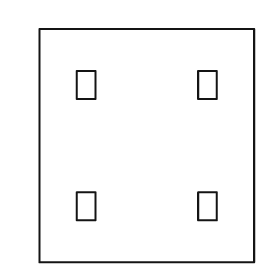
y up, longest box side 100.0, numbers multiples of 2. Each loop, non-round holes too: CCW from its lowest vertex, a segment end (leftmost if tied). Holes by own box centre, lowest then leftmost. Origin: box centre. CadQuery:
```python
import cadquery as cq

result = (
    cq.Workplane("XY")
    .moveTo(-46.0, -50.0)
    .lineTo(46.0, -50.0)
    .lineTo(46.0, 50.0)
    .lineTo(-46.0, 50.0)
    .close()
    .moveTo(-30.0, -32.0)
    .lineTo(-22.0, -32.0)
    .lineTo(-22.0, -20.0)
    .lineTo(-30.0, -20.0)
    .close()
    .moveTo(22.0, -32.0)
    .lineTo(30.0, -32.0)
    .lineTo(30.0, -20.0)
    .lineTo(22.0, -20.0)
    .close()
    .moveTo(-30.0, 20.0)
    .lineTo(-22.0, 20.0)
    .lineTo(-22.0, 32.0)
    .lineTo(-30.0, 32.0)
    .close()
    .moveTo(22.0, 20.0)
    .lineTo(30.0, 20.0)
    .lineTo(30.0, 32.0)
    .lineTo(22.0, 32.0)
    .close()
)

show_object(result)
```